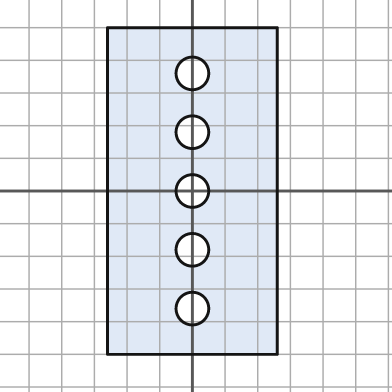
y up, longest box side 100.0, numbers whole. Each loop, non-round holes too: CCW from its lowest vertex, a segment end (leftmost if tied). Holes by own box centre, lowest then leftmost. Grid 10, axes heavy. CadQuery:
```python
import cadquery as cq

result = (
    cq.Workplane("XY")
    .moveTo(-26.0, -50.0)
    .lineTo(26.0, -50.0)
    .lineTo(26.0, 50.0)
    .lineTo(-26.0, 50.0)
    .close()
    .moveTo(0.0, -36.0)
    .circle(5.0)
    .moveTo(0.0, -18.0)
    .circle(5.0)
    .moveTo(0.0, 0.0)
    .circle(5.0)
    .moveTo(0.0, 18.0)
    .circle(5.0)
    .moveTo(0.0, 36.0)
    .circle(5.0)
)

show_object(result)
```